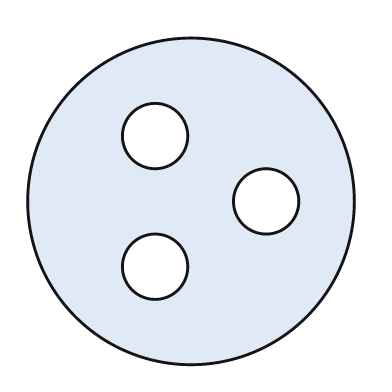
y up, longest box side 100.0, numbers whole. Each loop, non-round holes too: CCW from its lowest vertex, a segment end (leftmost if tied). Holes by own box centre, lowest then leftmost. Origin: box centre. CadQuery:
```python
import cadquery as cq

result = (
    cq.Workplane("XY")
    .moveTo(0.0, 0.0)
    .circle(50.0)
    .moveTo(-11.0, -20.0)
    .circle(10.0)
    .moveTo(23.0, 0.0)
    .circle(10.0)
    .moveTo(-11.0, 20.0)
    .circle(10.0)
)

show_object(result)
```